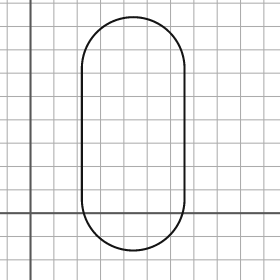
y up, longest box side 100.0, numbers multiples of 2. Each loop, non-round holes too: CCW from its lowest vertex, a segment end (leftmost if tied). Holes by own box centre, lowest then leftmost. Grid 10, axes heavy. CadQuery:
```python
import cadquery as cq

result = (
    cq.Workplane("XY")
    .moveTo(22.0, 6.0)
    .threePointArc((44.0, -16.0), (66.0, 6.0))
    .lineTo(66.0, 62.0)
    .threePointArc((44.0, 84.0), (22.0, 62.0))
    .close()
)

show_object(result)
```